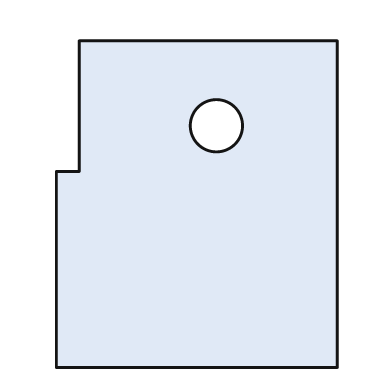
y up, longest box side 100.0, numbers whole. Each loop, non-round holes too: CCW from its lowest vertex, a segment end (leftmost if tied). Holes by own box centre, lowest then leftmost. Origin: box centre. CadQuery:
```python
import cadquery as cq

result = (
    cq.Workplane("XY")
    .moveTo(-43.0, -50.0)
    .lineTo(43.0, -50.0)
    .lineTo(43.0, 50.0)
    .lineTo(-36.0, 50.0)
    .lineTo(-36.0, 10.0)
    .lineTo(-43.0, 10.0)
    .close()
    .moveTo(6.0, 24.0)
    .circle(8.0)
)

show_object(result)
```